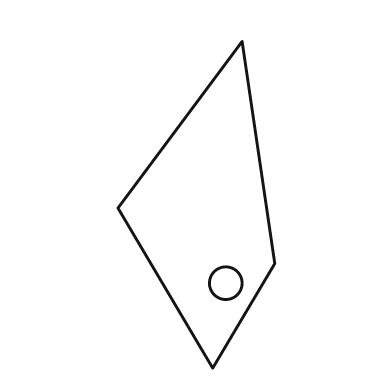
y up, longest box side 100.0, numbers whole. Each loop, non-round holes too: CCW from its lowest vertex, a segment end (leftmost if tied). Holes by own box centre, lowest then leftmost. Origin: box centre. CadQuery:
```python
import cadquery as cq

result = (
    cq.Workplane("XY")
    .moveTo(5.0, -50.0)
    .lineTo(24.0, -18.0)
    .lineTo(14.0, 50.0)
    .lineTo(-24.0, -1.0)
    .close()
    .moveTo(9.0, -24.0)
    .circle(5.0)
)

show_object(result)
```